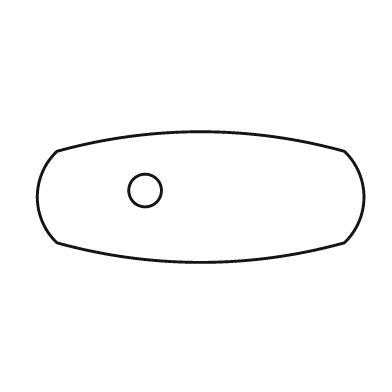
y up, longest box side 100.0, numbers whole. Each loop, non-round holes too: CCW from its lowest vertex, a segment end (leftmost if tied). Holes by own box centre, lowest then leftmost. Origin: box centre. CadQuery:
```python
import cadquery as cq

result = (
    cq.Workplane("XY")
    .moveTo(-44.0, -14.0)
    .threePointArc((0.0, -20.0), (44.0, -14.0))
    .threePointArc((50.0, 0.0), (44.0, 14.0))
    .threePointArc((0.0, 20.0), (-44.0, 14.0))
    .threePointArc((-50.0, 0.0), (-44.0, -14.0))
    .close()
    .moveTo(-17.0, 2.0)
    .circle(5.0)
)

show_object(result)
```